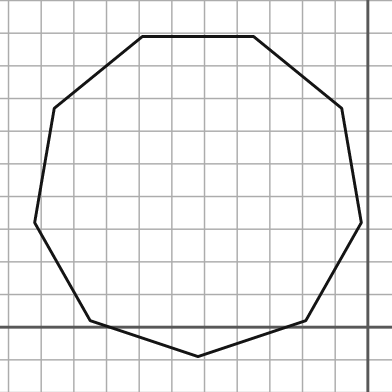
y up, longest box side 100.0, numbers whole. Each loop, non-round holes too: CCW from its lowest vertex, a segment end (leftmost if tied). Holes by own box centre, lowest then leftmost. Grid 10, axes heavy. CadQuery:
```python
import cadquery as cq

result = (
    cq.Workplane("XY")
    .moveTo(-52.0, -9.0)
    .lineTo(-19.0, 2.0)
    .lineTo(-2.0, 32.0)
    .lineTo(-8.0, 67.0)
    .lineTo(-35.0, 89.0)
    .lineTo(-69.0, 89.0)
    .lineTo(-96.0, 67.0)
    .lineTo(-102.0, 32.0)
    .lineTo(-85.0, 2.0)
    .close()
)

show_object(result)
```